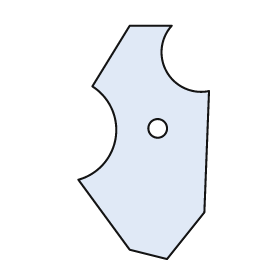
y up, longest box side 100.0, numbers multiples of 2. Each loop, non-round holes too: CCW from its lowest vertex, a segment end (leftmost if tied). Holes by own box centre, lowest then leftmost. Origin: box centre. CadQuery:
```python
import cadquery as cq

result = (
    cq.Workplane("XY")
    .moveTo(10.0, -50.0)
    .lineTo(26.0, -30.0)
    .lineTo(28.0, 22.0)
    .threePointArc((10.0, 30.0), (12.0, 50.0))
    .lineTo(-6.0, 50.0)
    .lineTo(-22.0, 24.0)
    .threePointArc((-12.0, 2.0), (-28.0, -16.0))
    .lineTo(-6.0, -46.0)
    .close()
    .moveTo(6.0, 6.0)
    .circle(4.0)
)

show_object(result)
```